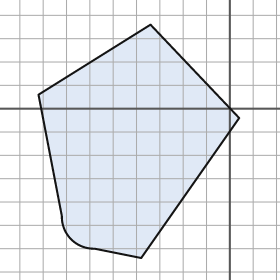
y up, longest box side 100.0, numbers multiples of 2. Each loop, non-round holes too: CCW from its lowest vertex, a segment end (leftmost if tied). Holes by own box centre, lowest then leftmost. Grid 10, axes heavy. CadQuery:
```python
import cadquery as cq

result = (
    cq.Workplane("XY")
    .moveTo(-38.0, -64.0)
    .lineTo(4.0, -4.0)
    .lineTo(-34.0, 36.0)
    .lineTo(-82.0, 6.0)
    .lineTo(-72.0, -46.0)
    .threePointArc((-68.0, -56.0), (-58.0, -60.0))
    .close()
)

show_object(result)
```